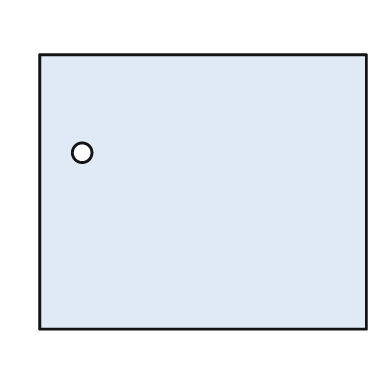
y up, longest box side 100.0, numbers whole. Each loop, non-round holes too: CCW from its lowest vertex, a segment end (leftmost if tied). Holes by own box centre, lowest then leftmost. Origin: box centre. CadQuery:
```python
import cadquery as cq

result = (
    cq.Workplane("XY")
    .moveTo(-50.0, -42.0)
    .lineTo(50.0, -42.0)
    .lineTo(50.0, 42.0)
    .lineTo(-50.0, 42.0)
    .close()
    .moveTo(-37.0, 12.0)
    .circle(3.0)
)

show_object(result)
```